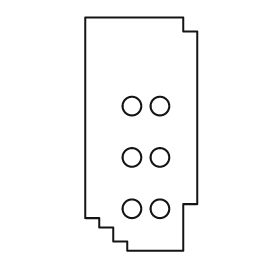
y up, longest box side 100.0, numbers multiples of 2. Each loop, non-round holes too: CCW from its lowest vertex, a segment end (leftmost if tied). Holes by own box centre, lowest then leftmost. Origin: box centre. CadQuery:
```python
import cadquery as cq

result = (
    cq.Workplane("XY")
    .moveTo(-6.0, -50.0)
    .lineTo(18.0, -50.0)
    .lineTo(18.0, -30.0)
    .lineTo(24.0, -30.0)
    .lineTo(24.0, 44.0)
    .lineTo(18.0, 44.0)
    .lineTo(18.0, 50.0)
    .lineTo(-24.0, 50.0)
    .lineTo(-24.0, -36.0)
    .lineTo(-18.0, -36.0)
    .lineTo(-18.0, -40.0)
    .lineTo(-12.0, -40.0)
    .lineTo(-12.0, -46.0)
    .lineTo(-6.0, -46.0)
    .close()
    .moveTo(-4.0, -32.0)
    .circle(4.0)
    .moveTo(8.0, -32.0)
    .circle(4.0)
    .moveTo(-4.0, -10.0)
    .circle(4.0)
    .moveTo(8.0, -10.0)
    .circle(4.0)
    .moveTo(-4.0, 12.0)
    .circle(4.0)
    .moveTo(8.0, 12.0)
    .circle(4.0)
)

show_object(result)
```